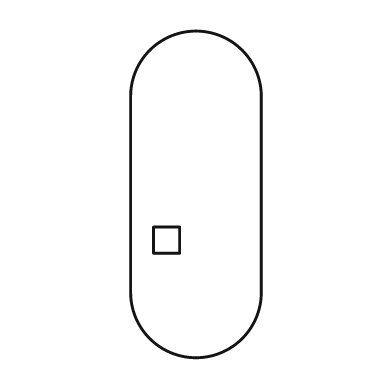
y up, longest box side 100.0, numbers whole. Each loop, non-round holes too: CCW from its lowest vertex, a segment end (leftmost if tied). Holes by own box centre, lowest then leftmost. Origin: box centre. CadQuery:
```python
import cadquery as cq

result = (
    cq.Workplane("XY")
    .moveTo(-20.0, -30.0)
    .threePointArc((0.0, -50.0), (20.0, -30.0))
    .lineTo(20.0, 30.0)
    .threePointArc((0.0, 50.0), (-20.0, 30.0))
    .close()
    .moveTo(-13.0, -18.0)
    .lineTo(-5.0, -18.0)
    .lineTo(-5.0, -10.0)
    .lineTo(-13.0, -10.0)
    .close()
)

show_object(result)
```